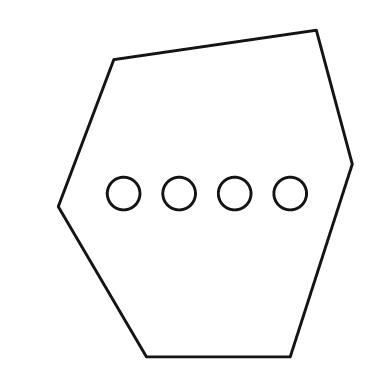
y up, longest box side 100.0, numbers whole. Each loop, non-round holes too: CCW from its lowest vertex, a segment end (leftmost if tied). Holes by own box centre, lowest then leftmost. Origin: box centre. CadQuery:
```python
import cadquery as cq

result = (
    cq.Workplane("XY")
    .moveTo(-18.0, -50.0)
    .lineTo(26.0, -50.0)
    .lineTo(45.0, 9.0)
    .lineTo(34.0, 50.0)
    .lineTo(-28.0, 41.0)
    .lineTo(-45.0, -4.0)
    .close()
    .moveTo(-25.0, 0.0)
    .circle(5.0)
    .moveTo(-8.0, 0.0)
    .circle(5.0)
    .moveTo(9.0, 0.0)
    .circle(5.0)
    .moveTo(26.0, 0.0)
    .circle(5.0)
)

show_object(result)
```